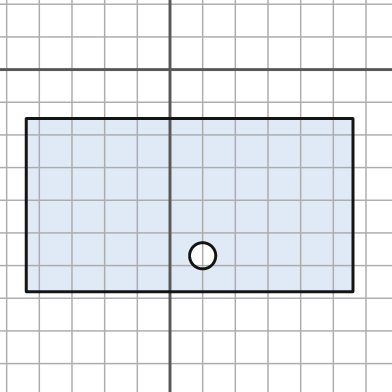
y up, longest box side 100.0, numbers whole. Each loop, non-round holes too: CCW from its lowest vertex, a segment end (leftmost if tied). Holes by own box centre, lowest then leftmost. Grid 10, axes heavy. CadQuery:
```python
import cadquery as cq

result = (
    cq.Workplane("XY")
    .moveTo(-44.0, -68.0)
    .lineTo(56.0, -68.0)
    .lineTo(56.0, -15.0)
    .lineTo(-44.0, -15.0)
    .close()
    .moveTo(10.0, -57.0)
    .circle(4.0)
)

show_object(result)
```